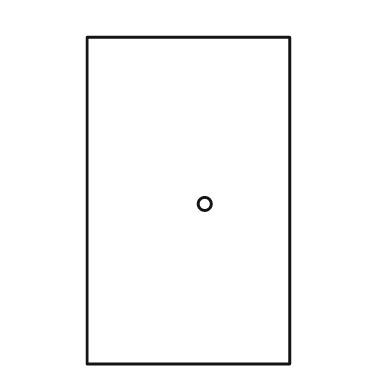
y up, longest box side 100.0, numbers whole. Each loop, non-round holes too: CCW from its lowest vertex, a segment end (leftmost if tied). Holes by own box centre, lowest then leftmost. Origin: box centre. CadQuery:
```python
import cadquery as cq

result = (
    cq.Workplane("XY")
    .moveTo(-31.0, -50.0)
    .lineTo(31.0, -50.0)
    .lineTo(31.0, 50.0)
    .lineTo(-31.0, 50.0)
    .close()
    .moveTo(5.0, -1.0)
    .circle(2.0)
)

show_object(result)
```